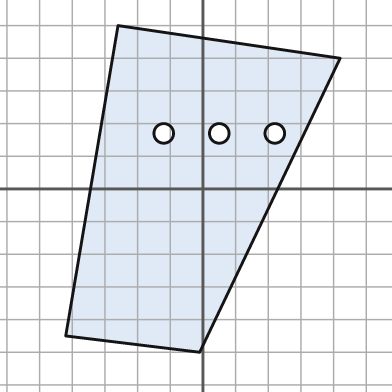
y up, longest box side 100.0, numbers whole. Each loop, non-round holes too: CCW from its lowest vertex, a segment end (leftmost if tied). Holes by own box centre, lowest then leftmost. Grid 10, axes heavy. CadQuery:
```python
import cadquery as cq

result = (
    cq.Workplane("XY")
    .moveTo(-1.0, -50.0)
    .lineTo(42.0, 40.0)
    .lineTo(-26.0, 50.0)
    .lineTo(-42.0, -45.0)
    .close()
    .moveTo(-12.0, 17.0)
    .circle(3.0)
    .moveTo(5.0, 17.0)
    .circle(3.0)
    .moveTo(22.0, 17.0)
    .circle(3.0)
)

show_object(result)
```